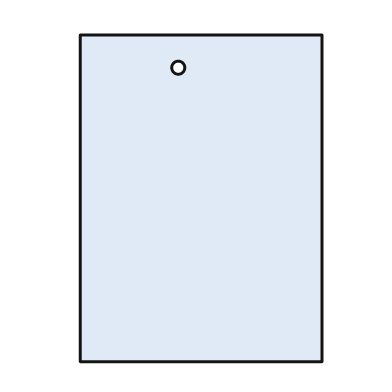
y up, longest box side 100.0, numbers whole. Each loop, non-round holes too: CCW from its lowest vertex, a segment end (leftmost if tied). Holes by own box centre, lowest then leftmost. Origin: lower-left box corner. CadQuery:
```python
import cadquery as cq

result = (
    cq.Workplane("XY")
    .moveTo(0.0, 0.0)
    .lineTo(74.0, 0.0)
    .lineTo(74.0, 100.0)
    .lineTo(0.0, 100.0)
    .close()
    .moveTo(30.0, 90.0)
    .circle(2.0)
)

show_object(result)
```